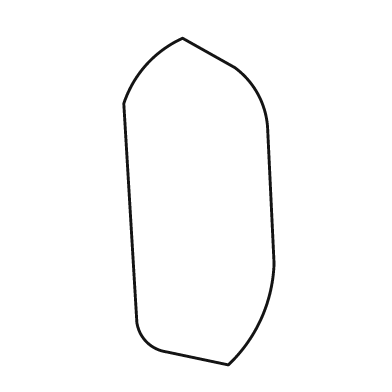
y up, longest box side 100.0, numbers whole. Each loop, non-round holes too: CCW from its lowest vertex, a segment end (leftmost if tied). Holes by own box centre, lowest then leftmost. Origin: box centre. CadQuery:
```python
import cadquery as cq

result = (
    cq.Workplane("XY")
    .moveTo(9.0, -50.0)
    .threePointArc((19.0, -36.0), (23.0, -19.0))
    .lineTo(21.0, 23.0)
    .threePointArc((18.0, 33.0), (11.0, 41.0))
    .lineTo(-5.0, 50.0)
    .threePointArc((-16.0, 42.0), (-23.0, 30.0))
    .lineTo(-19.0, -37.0)
    .threePointArc((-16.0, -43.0), (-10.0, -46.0))
    .close()
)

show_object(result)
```